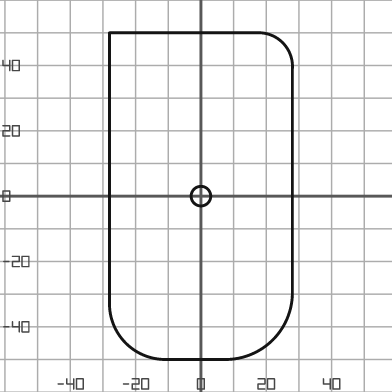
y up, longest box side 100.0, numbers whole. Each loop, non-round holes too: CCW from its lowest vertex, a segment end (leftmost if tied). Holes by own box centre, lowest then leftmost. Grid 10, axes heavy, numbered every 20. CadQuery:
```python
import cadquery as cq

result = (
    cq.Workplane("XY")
    .moveTo(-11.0, -50.0)
    .lineTo(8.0, -50.0)
    .threePointArc((22.0, -44.0), (28.0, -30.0))
    .lineTo(28.0, 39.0)
    .threePointArc((25.0, 47.0), (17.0, 50.0))
    .lineTo(-28.0, 50.0)
    .lineTo(-28.0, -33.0)
    .threePointArc((-23.0, -45.0), (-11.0, -50.0))
    .close()
    .moveTo(0.0, 0.0)
    .circle(3.0)
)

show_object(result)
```